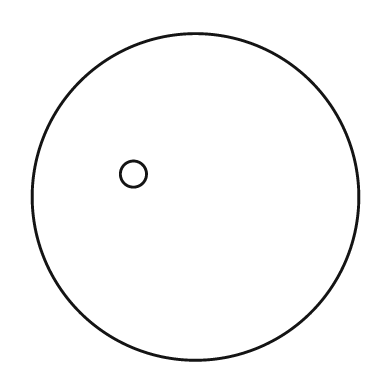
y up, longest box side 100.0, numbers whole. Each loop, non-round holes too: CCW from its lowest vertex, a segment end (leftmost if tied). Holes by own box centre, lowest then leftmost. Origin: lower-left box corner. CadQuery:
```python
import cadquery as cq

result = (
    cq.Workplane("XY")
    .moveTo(50.0, 50.0)
    .circle(50.0)
    .moveTo(31.0, 57.0)
    .circle(4.0)
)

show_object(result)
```